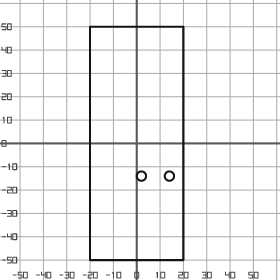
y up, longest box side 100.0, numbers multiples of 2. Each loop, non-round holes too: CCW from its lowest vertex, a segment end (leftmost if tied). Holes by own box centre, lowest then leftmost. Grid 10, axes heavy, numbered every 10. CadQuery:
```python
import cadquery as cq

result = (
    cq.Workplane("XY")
    .moveTo(-20.0, -50.0)
    .lineTo(20.0, -50.0)
    .lineTo(20.0, 50.0)
    .lineTo(-20.0, 50.0)
    .close()
    .moveTo(2.0, -14.0)
    .circle(2.0)
    .moveTo(14.0, -14.0)
    .circle(2.0)
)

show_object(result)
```